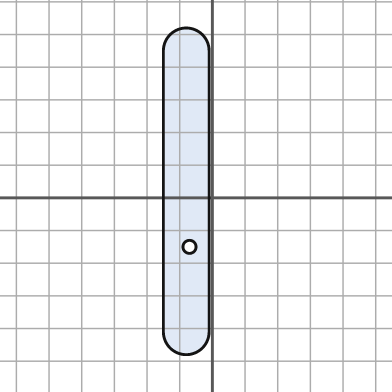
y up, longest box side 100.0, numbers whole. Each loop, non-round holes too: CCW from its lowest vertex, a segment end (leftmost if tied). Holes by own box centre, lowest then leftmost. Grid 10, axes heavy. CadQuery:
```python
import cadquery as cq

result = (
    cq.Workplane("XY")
    .moveTo(-15.0, -41.0)
    .threePointArc((-8.0, -48.0), (-1.0, -41.0))
    .lineTo(-1.0, 45.0)
    .threePointArc((-8.0, 52.0), (-15.0, 45.0))
    .close()
    .moveTo(-7.0, -15.0)
    .circle(2.0)
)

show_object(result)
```